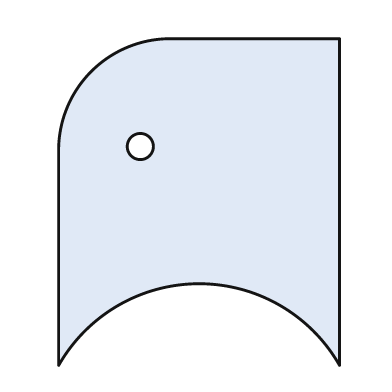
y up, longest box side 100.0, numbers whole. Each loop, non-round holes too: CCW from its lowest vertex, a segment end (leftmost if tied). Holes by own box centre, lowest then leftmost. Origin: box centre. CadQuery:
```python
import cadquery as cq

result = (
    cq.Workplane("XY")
    .moveTo(-43.0, -50.0)
    .threePointArc((0.0, -25.0), (43.0, -50.0))
    .lineTo(43.0, 50.0)
    .lineTo(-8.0, 50.0)
    .threePointArc((-33.0, 40.0), (-43.0, 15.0))
    .close()
    .moveTo(-18.0, 17.0)
    .circle(4.0)
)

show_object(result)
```